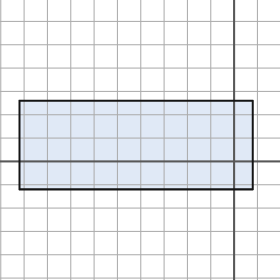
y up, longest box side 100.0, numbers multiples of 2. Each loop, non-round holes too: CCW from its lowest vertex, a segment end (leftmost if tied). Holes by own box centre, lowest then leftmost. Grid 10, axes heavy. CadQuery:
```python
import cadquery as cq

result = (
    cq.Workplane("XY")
    .moveTo(-92.0, -12.0)
    .lineTo(8.0, -12.0)
    .lineTo(8.0, 26.0)
    .lineTo(-92.0, 26.0)
    .close()
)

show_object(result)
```